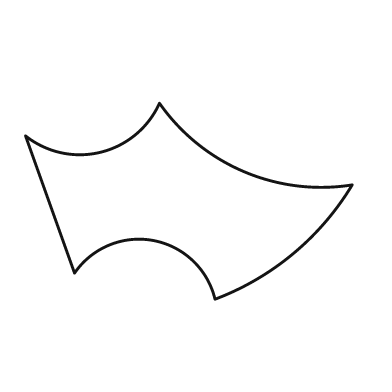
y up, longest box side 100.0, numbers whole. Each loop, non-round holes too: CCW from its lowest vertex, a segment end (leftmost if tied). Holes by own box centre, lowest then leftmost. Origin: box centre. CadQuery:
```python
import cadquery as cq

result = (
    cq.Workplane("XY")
    .moveTo(8.0, -30.0)
    .threePointArc((32.0, -16.0), (50.0, 5.0))
    .threePointArc((17.0, 9.0), (-9.0, 30.0))
    .threePointArc((-27.0, 15.0), (-50.0, 20.0))
    .lineTo(-35.0, -22.0)
    .threePointArc((-11.0, -12.0), (8.0, -30.0))
    .close()
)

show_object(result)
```